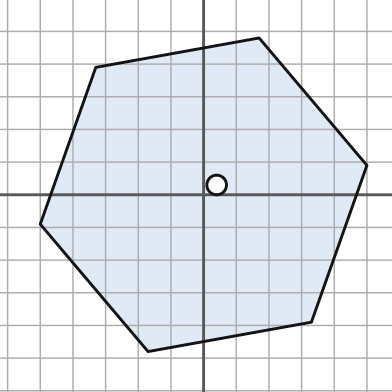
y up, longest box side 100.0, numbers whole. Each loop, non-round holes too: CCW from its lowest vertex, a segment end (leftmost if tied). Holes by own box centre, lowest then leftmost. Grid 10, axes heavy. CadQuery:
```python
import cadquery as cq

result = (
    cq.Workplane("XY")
    .moveTo(-17.0, -48.0)
    .lineTo(33.0, -39.0)
    .lineTo(50.0, 9.0)
    .lineTo(17.0, 48.0)
    .lineTo(-33.0, 39.0)
    .lineTo(-50.0, -9.0)
    .close()
    .moveTo(4.0, 3.0)
    .circle(3.0)
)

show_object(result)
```